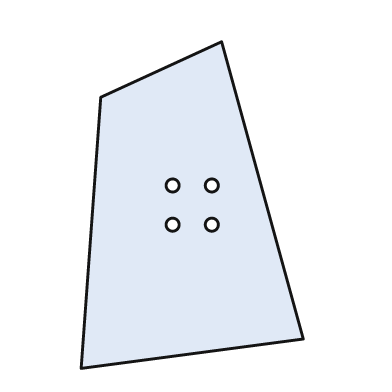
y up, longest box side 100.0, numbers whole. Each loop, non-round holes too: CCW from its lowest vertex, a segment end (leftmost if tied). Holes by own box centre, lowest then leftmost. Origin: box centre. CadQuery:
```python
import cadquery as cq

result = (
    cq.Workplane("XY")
    .moveTo(-34.0, -50.0)
    .lineTo(34.0, -41.0)
    .lineTo(9.0, 50.0)
    .lineTo(-28.0, 33.0)
    .close()
    .moveTo(-6.0, -6.0)
    .circle(2.0)
    .moveTo(6.0, -6.0)
    .circle(2.0)
    .moveTo(-6.0, 6.0)
    .circle(2.0)
    .moveTo(6.0, 6.0)
    .circle(2.0)
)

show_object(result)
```